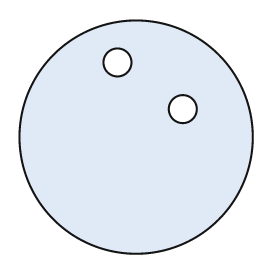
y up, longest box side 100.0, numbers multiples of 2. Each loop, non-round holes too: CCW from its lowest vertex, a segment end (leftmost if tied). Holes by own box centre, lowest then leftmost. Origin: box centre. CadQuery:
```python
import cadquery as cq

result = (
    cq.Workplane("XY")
    .moveTo(0.0, 0.0)
    .circle(50.0)
    .moveTo(20.0, 12.0)
    .circle(6.0)
    .moveTo(-8.0, 32.0)
    .circle(6.0)
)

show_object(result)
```